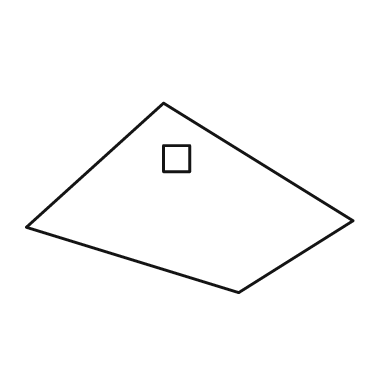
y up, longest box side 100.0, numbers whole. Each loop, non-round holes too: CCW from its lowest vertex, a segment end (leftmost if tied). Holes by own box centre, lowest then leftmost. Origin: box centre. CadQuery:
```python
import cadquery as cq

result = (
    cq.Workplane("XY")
    .moveTo(15.0, -29.0)
    .lineTo(50.0, -7.0)
    .lineTo(-8.0, 29.0)
    .lineTo(-50.0, -9.0)
    .close()
    .moveTo(-8.0, 8.0)
    .lineTo(0.0, 8.0)
    .lineTo(0.0, 16.0)
    .lineTo(-8.0, 16.0)
    .close()
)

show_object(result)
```